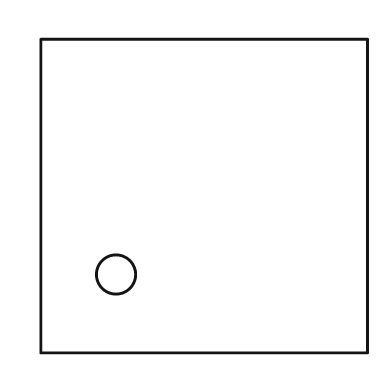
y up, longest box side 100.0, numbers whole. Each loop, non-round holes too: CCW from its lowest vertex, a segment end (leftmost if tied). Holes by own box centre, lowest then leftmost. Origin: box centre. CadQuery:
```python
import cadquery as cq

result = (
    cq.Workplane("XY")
    .moveTo(-50.0, -48.0)
    .lineTo(50.0, -48.0)
    .lineTo(50.0, 48.0)
    .lineTo(-50.0, 48.0)
    .close()
    .moveTo(-27.0, -24.0)
    .circle(6.0)
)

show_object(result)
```